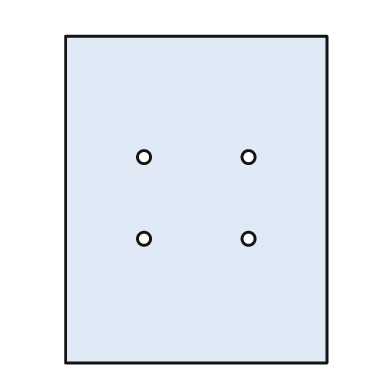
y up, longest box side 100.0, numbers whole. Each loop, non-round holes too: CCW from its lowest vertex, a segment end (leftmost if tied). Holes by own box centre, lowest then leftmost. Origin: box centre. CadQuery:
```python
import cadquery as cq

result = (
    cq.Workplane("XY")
    .moveTo(-40.0, -50.0)
    .lineTo(40.0, -50.0)
    .lineTo(40.0, 50.0)
    .lineTo(-40.0, 50.0)
    .close()
    .moveTo(-16.0, -12.0)
    .circle(2.0)
    .moveTo(16.0, -12.0)
    .circle(2.0)
    .moveTo(-16.0, 13.0)
    .circle(2.0)
    .moveTo(16.0, 13.0)
    .circle(2.0)
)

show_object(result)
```